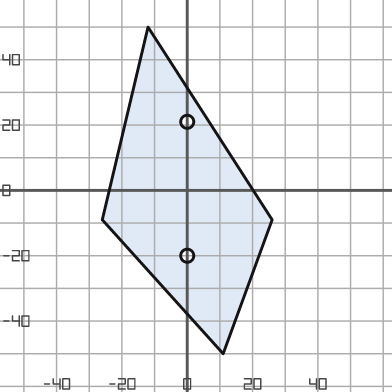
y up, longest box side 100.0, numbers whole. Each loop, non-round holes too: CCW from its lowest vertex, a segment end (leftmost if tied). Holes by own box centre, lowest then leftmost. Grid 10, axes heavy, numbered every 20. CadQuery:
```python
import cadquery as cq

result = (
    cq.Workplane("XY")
    .moveTo(11.0, -50.0)
    .lineTo(26.0, -9.0)
    .lineTo(-12.0, 50.0)
    .lineTo(-26.0, -9.0)
    .close()
    .moveTo(0.0, -20.0)
    .circle(2.0)
    .moveTo(0.0, 21.0)
    .circle(2.0)
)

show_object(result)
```